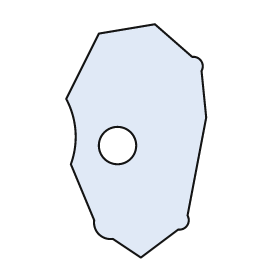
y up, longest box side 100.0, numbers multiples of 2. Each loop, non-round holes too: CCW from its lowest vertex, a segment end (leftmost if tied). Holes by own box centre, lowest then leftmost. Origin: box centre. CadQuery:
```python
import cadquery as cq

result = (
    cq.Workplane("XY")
    .moveTo(2.0, -50.0)
    .lineTo(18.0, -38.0)
    .threePointArc((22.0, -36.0), (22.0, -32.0))
    .lineTo(30.0, 10.0)
    .lineTo(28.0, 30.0)
    .threePointArc((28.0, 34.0), (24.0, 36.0))
    .lineTo(8.0, 50.0)
    .lineTo(-16.0, 46.0)
    .lineTo(-30.0, 18.0)
    .threePointArc((-26.0, 4.0), (-28.0, -10.0))
    .lineTo(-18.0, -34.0)
    .threePointArc((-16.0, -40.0), (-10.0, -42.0))
    .close()
    .moveTo(-8.0, -2.0)
    .circle(8.0)
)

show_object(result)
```